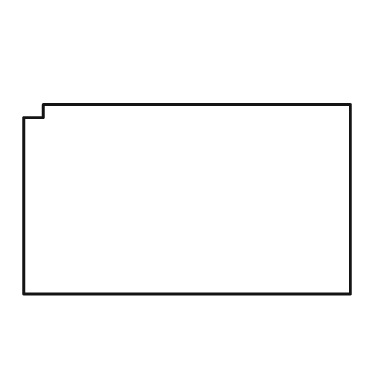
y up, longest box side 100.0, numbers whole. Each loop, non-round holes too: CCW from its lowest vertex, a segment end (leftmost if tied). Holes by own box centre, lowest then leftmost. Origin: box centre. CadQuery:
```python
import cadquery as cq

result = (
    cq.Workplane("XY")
    .moveTo(-50.0, -29.0)
    .lineTo(50.0, -29.0)
    .lineTo(50.0, 29.0)
    .lineTo(-44.0, 29.0)
    .lineTo(-44.0, 25.0)
    .lineTo(-50.0, 25.0)
    .close()
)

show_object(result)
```